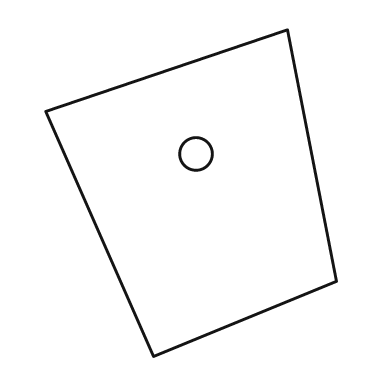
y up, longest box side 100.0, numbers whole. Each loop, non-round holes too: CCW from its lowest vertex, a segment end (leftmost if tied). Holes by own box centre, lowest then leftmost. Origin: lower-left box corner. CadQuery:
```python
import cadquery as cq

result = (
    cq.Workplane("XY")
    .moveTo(33.0, 0.0)
    .lineTo(89.0, 23.0)
    .lineTo(74.0, 100.0)
    .lineTo(0.0, 75.0)
    .close()
    .moveTo(46.0, 62.0)
    .circle(5.0)
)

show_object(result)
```